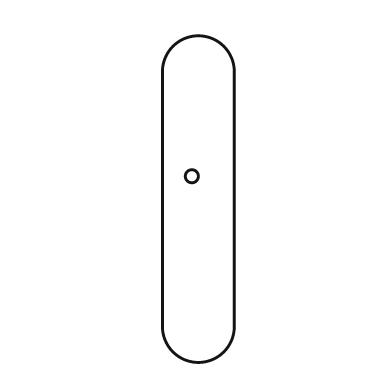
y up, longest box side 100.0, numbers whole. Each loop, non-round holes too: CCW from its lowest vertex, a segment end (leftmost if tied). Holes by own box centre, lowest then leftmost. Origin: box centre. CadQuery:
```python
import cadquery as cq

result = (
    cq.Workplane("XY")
    .moveTo(-11.0, -39.0)
    .threePointArc((0.0, -50.0), (11.0, -39.0))
    .lineTo(11.0, 39.0)
    .threePointArc((0.0, 50.0), (-11.0, 39.0))
    .close()
    .moveTo(-2.0, 7.0)
    .circle(2.0)
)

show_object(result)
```